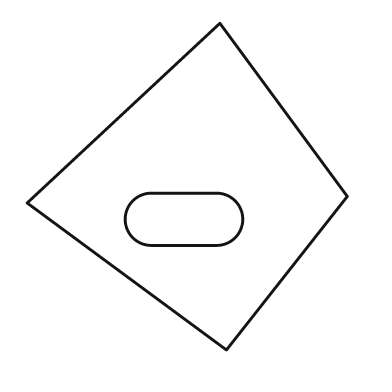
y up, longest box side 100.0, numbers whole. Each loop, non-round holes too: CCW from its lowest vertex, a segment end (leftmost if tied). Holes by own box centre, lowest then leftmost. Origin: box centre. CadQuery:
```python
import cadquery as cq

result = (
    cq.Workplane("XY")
    .moveTo(12.0, -50.0)
    .lineTo(49.0, -3.0)
    .lineTo(10.0, 50.0)
    .lineTo(-49.0, -5.0)
    .close()
    .moveTo(-11.0, -18.0)
    .lineTo(9.0, -18.0)
    .threePointArc((17.0, -10.0), (9.0, -2.0))
    .lineTo(-11.0, -2.0)
    .threePointArc((-19.0, -10.0), (-11.0, -18.0))
    .close()
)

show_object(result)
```